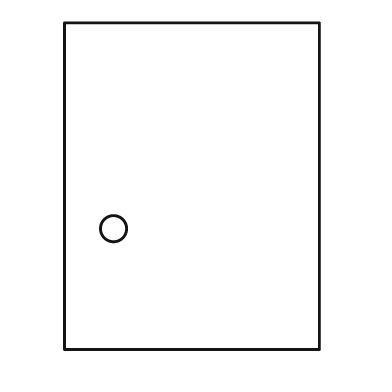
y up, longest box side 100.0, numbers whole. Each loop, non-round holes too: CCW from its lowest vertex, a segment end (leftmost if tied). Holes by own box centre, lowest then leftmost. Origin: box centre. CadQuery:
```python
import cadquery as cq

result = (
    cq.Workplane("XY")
    .moveTo(-39.0, -50.0)
    .lineTo(39.0, -50.0)
    .lineTo(39.0, 50.0)
    .lineTo(-39.0, 50.0)
    .close()
    .moveTo(-24.0, -13.0)
    .circle(4.0)
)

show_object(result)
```